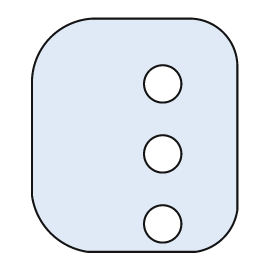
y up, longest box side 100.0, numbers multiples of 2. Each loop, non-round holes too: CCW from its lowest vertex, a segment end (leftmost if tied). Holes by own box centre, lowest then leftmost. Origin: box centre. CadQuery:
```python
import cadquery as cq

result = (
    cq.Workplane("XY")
    .moveTo(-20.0, -50.0)
    .lineTo(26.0, -50.0)
    .threePointArc((38.0, -44.0), (44.0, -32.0))
    .lineTo(44.0, 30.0)
    .threePointArc((38.0, 44.0), (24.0, 50.0))
    .lineTo(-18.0, 50.0)
    .threePointArc((-36.0, 42.0), (-44.0, 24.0))
    .lineTo(-44.0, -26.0)
    .threePointArc((-36.0, -42.0), (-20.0, -50.0))
    .close()
    .moveTo(12.0, -38.0)
    .circle(8.0)
    .moveTo(12.0, -8.0)
    .circle(8.0)
    .moveTo(12.0, 22.0)
    .circle(8.0)
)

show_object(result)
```